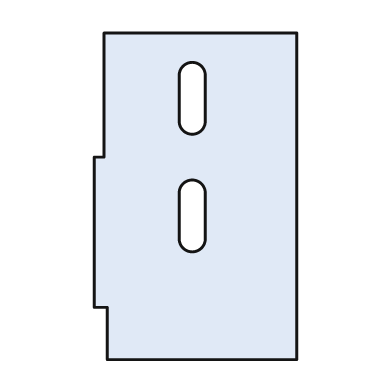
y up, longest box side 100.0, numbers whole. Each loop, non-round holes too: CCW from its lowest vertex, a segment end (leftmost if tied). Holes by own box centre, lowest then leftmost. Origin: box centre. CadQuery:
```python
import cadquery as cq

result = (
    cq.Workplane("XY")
    .moveTo(-27.0, -50.0)
    .lineTo(31.0, -50.0)
    .lineTo(31.0, 50.0)
    .lineTo(-28.0, 50.0)
    .lineTo(-28.0, 12.0)
    .lineTo(-31.0, 12.0)
    .lineTo(-31.0, -34.0)
    .lineTo(-27.0, -34.0)
    .close()
    .moveTo(-5.0, -13.0)
    .threePointArc((-1.0, -17.0), (3.0, -13.0))
    .lineTo(3.0, 1.0)
    .threePointArc((-1.0, 5.0), (-5.0, 1.0))
    .close()
    .moveTo(-5.0, 23.0)
    .threePointArc((-1.0, 19.0), (3.0, 23.0))
    .lineTo(3.0, 37.0)
    .threePointArc((-1.0, 41.0), (-5.0, 37.0))
    .close()
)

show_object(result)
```